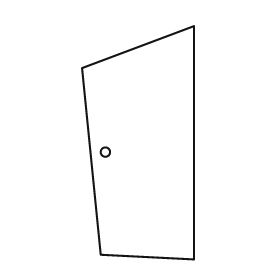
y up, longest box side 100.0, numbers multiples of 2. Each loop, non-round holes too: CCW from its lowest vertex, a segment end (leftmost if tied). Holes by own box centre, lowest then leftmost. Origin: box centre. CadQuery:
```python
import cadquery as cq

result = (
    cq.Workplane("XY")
    .moveTo(24.0, -50.0)
    .lineTo(24.0, 50.0)
    .lineTo(-24.0, 32.0)
    .lineTo(-16.0, -48.0)
    .close()
    .moveTo(-14.0, -4.0)
    .circle(2.0)
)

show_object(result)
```